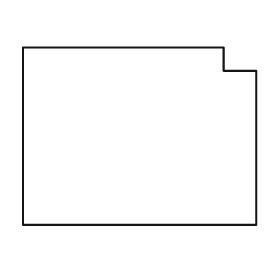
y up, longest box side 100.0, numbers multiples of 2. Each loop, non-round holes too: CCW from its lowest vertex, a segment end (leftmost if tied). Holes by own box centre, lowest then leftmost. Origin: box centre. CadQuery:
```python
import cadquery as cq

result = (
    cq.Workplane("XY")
    .moveTo(-50.0, -38.0)
    .lineTo(50.0, -38.0)
    .lineTo(50.0, 28.0)
    .lineTo(36.0, 28.0)
    .lineTo(36.0, 38.0)
    .lineTo(-50.0, 38.0)
    .close()
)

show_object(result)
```